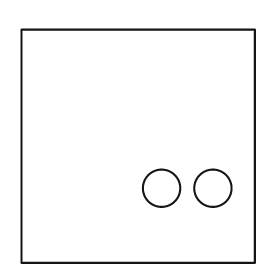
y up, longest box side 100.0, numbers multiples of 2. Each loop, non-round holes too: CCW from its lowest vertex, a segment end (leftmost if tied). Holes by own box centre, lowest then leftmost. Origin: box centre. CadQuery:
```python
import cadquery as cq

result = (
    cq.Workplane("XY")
    .moveTo(-50.0, -50.0)
    .lineTo(50.0, -50.0)
    .lineTo(50.0, 50.0)
    .lineTo(-50.0, 50.0)
    .close()
    .moveTo(10.0, -18.0)
    .circle(8.0)
    .moveTo(32.0, -18.0)
    .circle(8.0)
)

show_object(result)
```